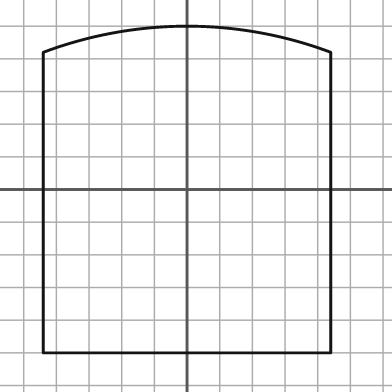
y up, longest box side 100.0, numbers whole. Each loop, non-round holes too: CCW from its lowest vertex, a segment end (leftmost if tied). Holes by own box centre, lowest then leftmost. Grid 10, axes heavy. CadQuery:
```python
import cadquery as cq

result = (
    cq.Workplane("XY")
    .moveTo(-44.0, -50.0)
    .lineTo(44.0, -50.0)
    .lineTo(44.0, 42.0)
    .threePointArc((0.0, 50.0), (-44.0, 42.0))
    .close()
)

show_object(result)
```